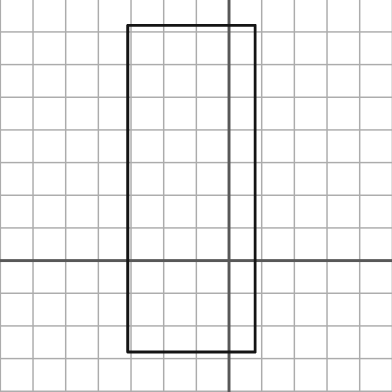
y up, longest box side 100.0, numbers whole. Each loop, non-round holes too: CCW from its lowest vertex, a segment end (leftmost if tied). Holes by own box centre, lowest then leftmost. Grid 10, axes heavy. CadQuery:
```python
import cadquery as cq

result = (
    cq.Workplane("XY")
    .moveTo(-31.0, -28.0)
    .lineTo(8.0, -28.0)
    .lineTo(8.0, 72.0)
    .lineTo(-31.0, 72.0)
    .close()
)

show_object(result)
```